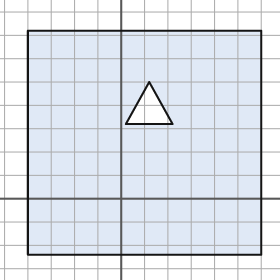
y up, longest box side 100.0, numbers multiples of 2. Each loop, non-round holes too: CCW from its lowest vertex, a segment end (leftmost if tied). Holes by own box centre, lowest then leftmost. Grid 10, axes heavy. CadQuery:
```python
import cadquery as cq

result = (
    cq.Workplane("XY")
    .moveTo(-40.0, -24.0)
    .lineTo(60.0, -24.0)
    .lineTo(60.0, 72.0)
    .lineTo(-40.0, 72.0)
    .close()
    .moveTo(2.0, 32.0)
    .lineTo(22.0, 32.0)
    .lineTo(12.0, 50.0)
    .close()
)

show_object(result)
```